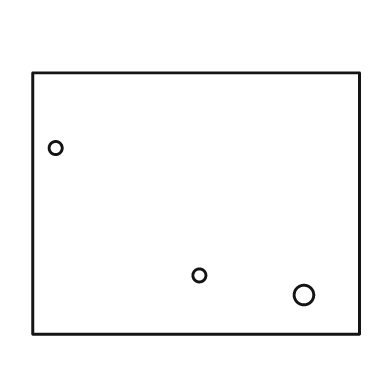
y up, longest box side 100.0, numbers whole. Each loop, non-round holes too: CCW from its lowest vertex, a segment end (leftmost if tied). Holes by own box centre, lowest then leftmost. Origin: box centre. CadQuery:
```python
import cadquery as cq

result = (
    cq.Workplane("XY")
    .moveTo(-50.0, -40.0)
    .lineTo(50.0, -40.0)
    .lineTo(50.0, 40.0)
    .lineTo(-50.0, 40.0)
    .close()
    .moveTo(33.0, -28.0)
    .circle(3.0)
    .moveTo(1.0, -22.0)
    .circle(2.0)
    .moveTo(-43.0, 17.0)
    .circle(2.0)
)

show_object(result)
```